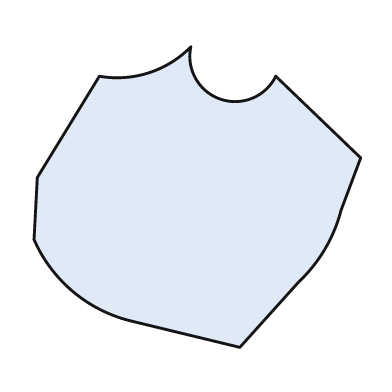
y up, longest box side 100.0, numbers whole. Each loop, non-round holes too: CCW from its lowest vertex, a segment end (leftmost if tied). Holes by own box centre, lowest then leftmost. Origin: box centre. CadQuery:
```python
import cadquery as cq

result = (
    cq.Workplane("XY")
    .moveTo(13.0, -46.0)
    .lineTo(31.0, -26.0)
    .threePointArc((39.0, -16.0), (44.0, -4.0))
    .lineTo(50.0, 12.0)
    .lineTo(24.0, 37.0)
    .threePointArc((7.0, 30.0), (-2.0, 46.0))
    .threePointArc((-15.0, 38.0), (-30.0, 37.0))
    .lineTo(-49.0, 6.0)
    .lineTo(-50.0, -13.0)
    .threePointArc((-38.0, -29.0), (-20.0, -38.0))
    .close()
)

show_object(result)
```